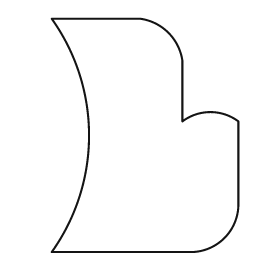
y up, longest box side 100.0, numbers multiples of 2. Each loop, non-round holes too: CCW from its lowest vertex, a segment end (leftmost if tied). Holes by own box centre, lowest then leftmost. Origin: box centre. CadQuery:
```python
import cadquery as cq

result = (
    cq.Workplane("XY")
    .moveTo(-40.0, -50.0)
    .lineTo(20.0, -50.0)
    .threePointArc((34.0, -44.0), (40.0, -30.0))
    .lineTo(40.0, 6.0)
    .threePointArc((28.0, 10.0), (16.0, 6.0))
    .lineTo(16.0, 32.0)
    .threePointArc((10.0, 44.0), (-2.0, 50.0))
    .lineTo(-40.0, 50.0)
    .threePointArc((-24.0, 0.0), (-40.0, -50.0))
    .close()
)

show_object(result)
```